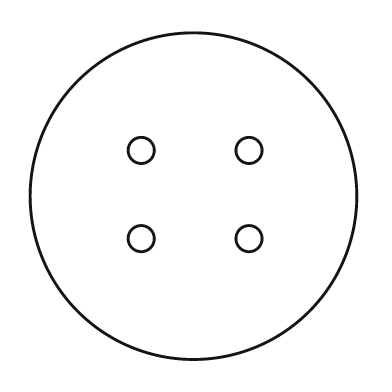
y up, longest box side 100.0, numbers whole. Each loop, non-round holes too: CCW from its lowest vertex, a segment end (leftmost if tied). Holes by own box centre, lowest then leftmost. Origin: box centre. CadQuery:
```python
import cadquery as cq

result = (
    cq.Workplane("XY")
    .moveTo(0.0, 0.0)
    .circle(50.0)
    .moveTo(-16.0, -13.0)
    .circle(4.0)
    .moveTo(17.0, -13.0)
    .circle(4.0)
    .moveTo(-16.0, 14.0)
    .circle(4.0)
    .moveTo(17.0, 14.0)
    .circle(4.0)
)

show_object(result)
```